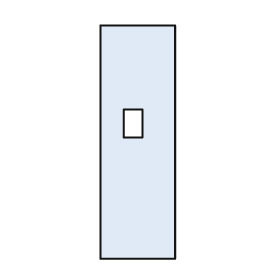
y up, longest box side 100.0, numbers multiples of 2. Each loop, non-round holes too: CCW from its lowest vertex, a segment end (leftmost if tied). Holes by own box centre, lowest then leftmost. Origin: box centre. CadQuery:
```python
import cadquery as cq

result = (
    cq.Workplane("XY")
    .moveTo(-16.0, -50.0)
    .lineTo(16.0, -50.0)
    .lineTo(16.0, 50.0)
    .lineTo(-16.0, 50.0)
    .close()
    .moveTo(-6.0, 2.0)
    .lineTo(2.0, 2.0)
    .lineTo(2.0, 14.0)
    .lineTo(-6.0, 14.0)
    .close()
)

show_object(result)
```